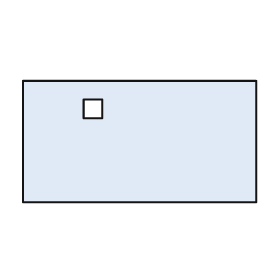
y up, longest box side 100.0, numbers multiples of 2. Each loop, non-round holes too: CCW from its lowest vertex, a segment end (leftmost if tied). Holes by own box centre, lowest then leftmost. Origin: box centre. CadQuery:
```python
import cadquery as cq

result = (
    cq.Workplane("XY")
    .moveTo(-50.0, -26.0)
    .lineTo(50.0, -26.0)
    .lineTo(50.0, 26.0)
    .lineTo(-50.0, 26.0)
    .close()
    .moveTo(-24.0, 10.0)
    .lineTo(-16.0, 10.0)
    .lineTo(-16.0, 18.0)
    .lineTo(-24.0, 18.0)
    .close()
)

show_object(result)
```